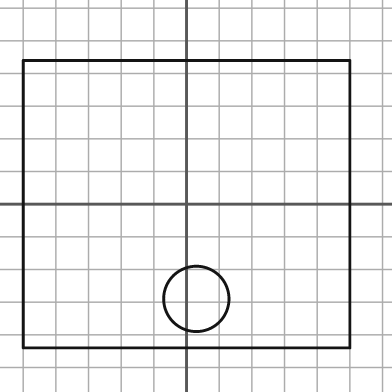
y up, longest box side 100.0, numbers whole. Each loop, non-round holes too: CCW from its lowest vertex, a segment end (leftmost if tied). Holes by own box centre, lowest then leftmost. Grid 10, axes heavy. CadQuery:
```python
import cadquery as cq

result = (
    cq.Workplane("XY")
    .moveTo(-50.0, -44.0)
    .lineTo(50.0, -44.0)
    .lineTo(50.0, 44.0)
    .lineTo(-50.0, 44.0)
    .close()
    .moveTo(3.0, -29.0)
    .circle(10.0)
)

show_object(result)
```